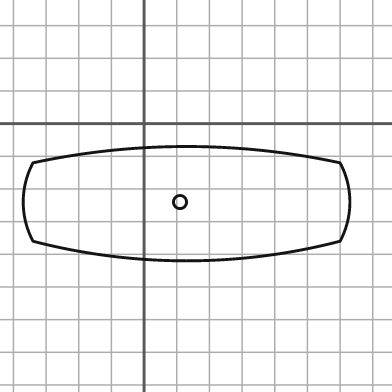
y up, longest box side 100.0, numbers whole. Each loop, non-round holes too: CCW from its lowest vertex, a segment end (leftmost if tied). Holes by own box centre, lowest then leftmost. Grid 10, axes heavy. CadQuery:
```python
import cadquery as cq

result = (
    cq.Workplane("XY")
    .moveTo(-34.0, -36.0)
    .threePointArc((13.0, -42.0), (60.0, -36.0))
    .threePointArc((63.0, -24.0), (60.0, -12.0))
    .threePointArc((13.0, -7.0), (-34.0, -12.0))
    .threePointArc((-37.0, -24.0), (-34.0, -36.0))
    .close()
    .moveTo(11.0, -24.0)
    .circle(2.0)
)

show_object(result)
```